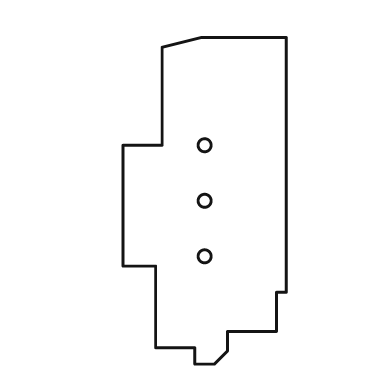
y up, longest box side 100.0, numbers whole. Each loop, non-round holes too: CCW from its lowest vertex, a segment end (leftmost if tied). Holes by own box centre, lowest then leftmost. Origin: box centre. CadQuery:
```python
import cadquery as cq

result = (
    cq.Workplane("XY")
    .moveTo(-3.0, -50.0)
    .lineTo(3.0, -50.0)
    .lineTo(7.0, -46.0)
    .lineTo(7.0, -40.0)
    .lineTo(22.0, -40.0)
    .lineTo(22.0, -28.0)
    .lineTo(25.0, -28.0)
    .lineTo(25.0, 50.0)
    .lineTo(-1.0, 50.0)
    .lineTo(-13.0, 47.0)
    .lineTo(-13.0, 17.0)
    .lineTo(-25.0, 17.0)
    .lineTo(-25.0, -20.0)
    .lineTo(-15.0, -20.0)
    .lineTo(-15.0, -45.0)
    .lineTo(-3.0, -45.0)
    .close()
    .moveTo(0.0, -17.0)
    .circle(2.0)
    .moveTo(0.0, 0.0)
    .circle(2.0)
    .moveTo(0.0, 17.0)
    .circle(2.0)
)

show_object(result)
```